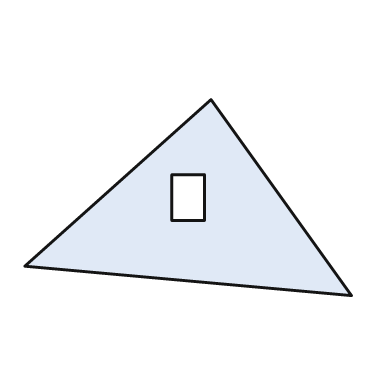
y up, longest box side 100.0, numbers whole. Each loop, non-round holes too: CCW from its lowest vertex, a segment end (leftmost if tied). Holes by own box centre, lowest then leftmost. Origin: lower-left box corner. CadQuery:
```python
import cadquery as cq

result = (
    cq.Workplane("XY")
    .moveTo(100.0, 0.0)
    .lineTo(57.0, 60.0)
    .lineTo(0.0, 9.0)
    .close()
    .moveTo(45.0, 23.0)
    .lineTo(55.0, 23.0)
    .lineTo(55.0, 37.0)
    .lineTo(45.0, 37.0)
    .close()
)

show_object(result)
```